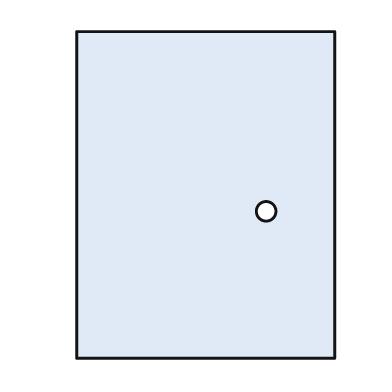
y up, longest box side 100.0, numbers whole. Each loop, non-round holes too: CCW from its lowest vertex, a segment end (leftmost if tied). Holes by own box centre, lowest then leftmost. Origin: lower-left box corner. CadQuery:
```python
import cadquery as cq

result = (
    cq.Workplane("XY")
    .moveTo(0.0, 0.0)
    .lineTo(79.0, 0.0)
    .lineTo(79.0, 100.0)
    .lineTo(0.0, 100.0)
    .close()
    .moveTo(58.0, 45.0)
    .circle(3.0)
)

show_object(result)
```